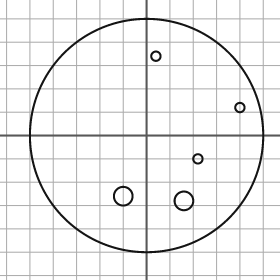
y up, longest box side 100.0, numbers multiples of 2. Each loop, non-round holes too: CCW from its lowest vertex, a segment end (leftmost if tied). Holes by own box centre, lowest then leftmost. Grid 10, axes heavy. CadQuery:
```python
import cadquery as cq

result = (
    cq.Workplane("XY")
    .moveTo(0.0, 0.0)
    .circle(50.0)
    .moveTo(16.0, -28.0)
    .circle(4.0)
    .moveTo(-10.0, -26.0)
    .circle(4.0)
    .moveTo(22.0, -10.0)
    .circle(2.0)
    .moveTo(40.0, 12.0)
    .circle(2.0)
    .moveTo(4.0, 34.0)
    .circle(2.0)
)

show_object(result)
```